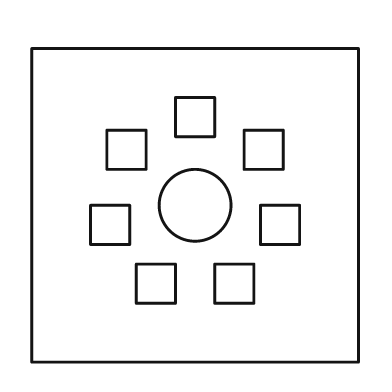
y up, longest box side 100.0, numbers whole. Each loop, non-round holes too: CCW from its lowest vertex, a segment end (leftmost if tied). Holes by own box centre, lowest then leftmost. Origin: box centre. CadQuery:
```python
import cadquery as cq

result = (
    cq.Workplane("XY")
    .moveTo(-50.0, -48.0)
    .lineTo(50.0, -48.0)
    .lineTo(50.0, 48.0)
    .lineTo(-50.0, 48.0)
    .close()
    .moveTo(-18.0, -30.0)
    .lineTo(-6.0, -30.0)
    .lineTo(-6.0, -18.0)
    .lineTo(-18.0, -18.0)
    .close()
    .moveTo(6.0, -30.0)
    .lineTo(18.0, -30.0)
    .lineTo(18.0, -18.0)
    .lineTo(6.0, -18.0)
    .close()
    .moveTo(-32.0, -12.0)
    .lineTo(-20.0, -12.0)
    .lineTo(-20.0, 0.0)
    .lineTo(-32.0, 0.0)
    .close()
    .moveTo(20.0, -12.0)
    .lineTo(32.0, -12.0)
    .lineTo(32.0, 0.0)
    .lineTo(20.0, 0.0)
    .close()
    .moveTo(0.0, 0.0)
    .circle(11.0)
    .moveTo(-27.0, 11.0)
    .lineTo(-15.0, 11.0)
    .lineTo(-15.0, 23.0)
    .lineTo(-27.0, 23.0)
    .close()
    .moveTo(15.0, 11.0)
    .lineTo(27.0, 11.0)
    .lineTo(27.0, 23.0)
    .lineTo(15.0, 23.0)
    .close()
    .moveTo(-6.0, 21.0)
    .lineTo(6.0, 21.0)
    .lineTo(6.0, 33.0)
    .lineTo(-6.0, 33.0)
    .close()
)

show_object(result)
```